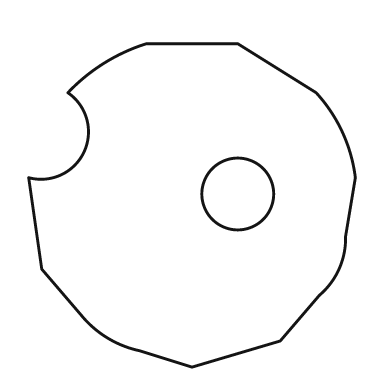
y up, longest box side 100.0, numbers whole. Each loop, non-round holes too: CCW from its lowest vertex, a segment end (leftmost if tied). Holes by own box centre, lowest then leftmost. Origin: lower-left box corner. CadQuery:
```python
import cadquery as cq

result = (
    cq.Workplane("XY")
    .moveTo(50.0, 0.0)
    .lineTo(77.0, 8.0)
    .lineTo(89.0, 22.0)
    .threePointArc((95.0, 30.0), (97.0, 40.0))
    .lineTo(100.0, 58.0)
    .threePointArc((96.0, 72.0), (88.0, 84.0))
    .lineTo(64.0, 99.0)
    .lineTo(36.0, 99.0)
    .threePointArc((23.0, 93.0), (12.0, 84.0))
    .threePointArc((17.0, 66.0), (0.0, 58.0))
    .lineTo(4.0, 30.0)
    .lineTo(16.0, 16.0)
    .threePointArc((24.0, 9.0), (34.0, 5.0))
    .close()
    .moveTo(64.0, 53.0)
    .circle(11.0)
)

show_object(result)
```